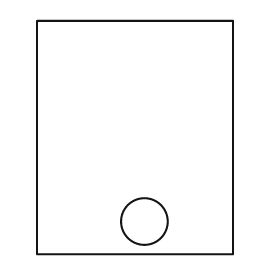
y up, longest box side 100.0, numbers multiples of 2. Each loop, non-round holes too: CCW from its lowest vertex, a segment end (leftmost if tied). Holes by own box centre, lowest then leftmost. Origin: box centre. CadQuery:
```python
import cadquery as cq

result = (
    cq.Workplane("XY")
    .moveTo(-42.0, -50.0)
    .lineTo(42.0, -50.0)
    .lineTo(42.0, 50.0)
    .lineTo(-42.0, 50.0)
    .close()
    .moveTo(4.0, -36.0)
    .circle(10.0)
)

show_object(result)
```